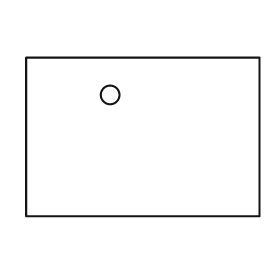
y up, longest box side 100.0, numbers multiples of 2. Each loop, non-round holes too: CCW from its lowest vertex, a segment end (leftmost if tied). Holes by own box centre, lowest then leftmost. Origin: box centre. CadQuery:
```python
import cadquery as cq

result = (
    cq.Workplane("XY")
    .moveTo(-50.0, -34.0)
    .lineTo(50.0, -34.0)
    .lineTo(50.0, 34.0)
    .lineTo(-50.0, 34.0)
    .close()
    .moveTo(-14.0, 18.0)
    .circle(4.0)
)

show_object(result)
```